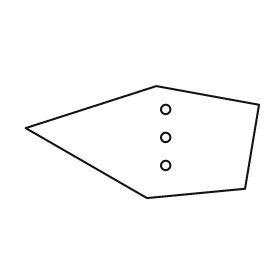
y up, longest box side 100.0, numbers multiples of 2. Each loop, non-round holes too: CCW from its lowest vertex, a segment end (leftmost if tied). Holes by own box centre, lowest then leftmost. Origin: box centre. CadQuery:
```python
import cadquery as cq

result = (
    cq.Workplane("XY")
    .moveTo(2.0, -24.0)
    .lineTo(44.0, -20.0)
    .lineTo(50.0, 16.0)
    .lineTo(6.0, 24.0)
    .lineTo(-50.0, 6.0)
    .close()
    .moveTo(10.0, -10.0)
    .circle(2.0)
    .moveTo(10.0, 2.0)
    .circle(2.0)
    .moveTo(10.0, 14.0)
    .circle(2.0)
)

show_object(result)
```